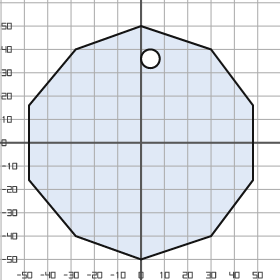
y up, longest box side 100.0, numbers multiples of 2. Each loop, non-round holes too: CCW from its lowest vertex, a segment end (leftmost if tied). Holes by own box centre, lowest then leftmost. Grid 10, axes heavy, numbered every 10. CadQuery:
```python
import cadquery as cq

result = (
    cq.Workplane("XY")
    .moveTo(0.0, -50.0)
    .lineTo(30.0, -40.0)
    .lineTo(48.0, -16.0)
    .lineTo(48.0, 16.0)
    .lineTo(30.0, 40.0)
    .lineTo(0.0, 50.0)
    .lineTo(-28.0, 40.0)
    .lineTo(-48.0, 16.0)
    .lineTo(-48.0, -16.0)
    .lineTo(-28.0, -40.0)
    .close()
    .moveTo(4.0, 36.0)
    .circle(4.0)
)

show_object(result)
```